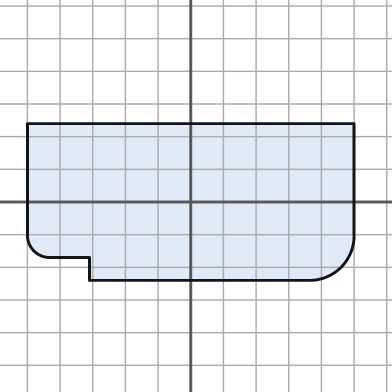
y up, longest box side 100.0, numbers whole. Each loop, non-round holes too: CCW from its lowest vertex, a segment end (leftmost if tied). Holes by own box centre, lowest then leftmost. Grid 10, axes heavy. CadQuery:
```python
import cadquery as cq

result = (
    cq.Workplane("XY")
    .moveTo(-31.0, -24.0)
    .lineTo(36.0, -24.0)
    .threePointArc((46.0, -20.0), (50.0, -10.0))
    .lineTo(50.0, 24.0)
    .lineTo(-50.0, 24.0)
    .lineTo(-50.0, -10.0)
    .threePointArc((-48.0, -15.0), (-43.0, -17.0))
    .lineTo(-31.0, -17.0)
    .close()
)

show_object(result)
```